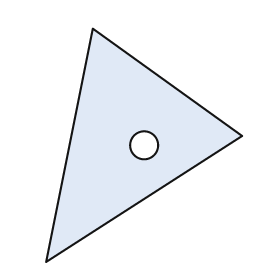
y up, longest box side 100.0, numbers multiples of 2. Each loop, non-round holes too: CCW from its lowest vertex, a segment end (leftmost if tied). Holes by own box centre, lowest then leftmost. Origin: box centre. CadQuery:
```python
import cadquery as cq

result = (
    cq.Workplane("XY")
    .moveTo(-42.0, -50.0)
    .lineTo(42.0, 4.0)
    .lineTo(-22.0, 50.0)
    .close()
    .moveTo(0.0, 0.0)
    .circle(6.0)
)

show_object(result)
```